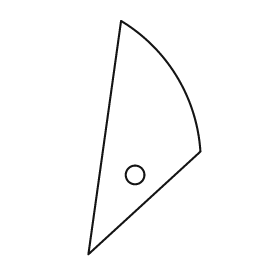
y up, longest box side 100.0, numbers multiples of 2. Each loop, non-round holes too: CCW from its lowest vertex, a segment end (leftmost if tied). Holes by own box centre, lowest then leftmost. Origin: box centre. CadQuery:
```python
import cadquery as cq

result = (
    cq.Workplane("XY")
    .moveTo(-24.0, -50.0)
    .lineTo(24.0, -6.0)
    .threePointArc((14.0, 26.0), (-10.0, 50.0))
    .close()
    .moveTo(-4.0, -16.0)
    .circle(4.0)
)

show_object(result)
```